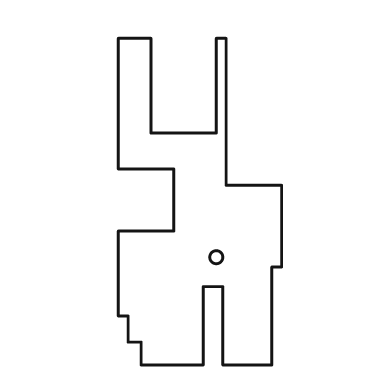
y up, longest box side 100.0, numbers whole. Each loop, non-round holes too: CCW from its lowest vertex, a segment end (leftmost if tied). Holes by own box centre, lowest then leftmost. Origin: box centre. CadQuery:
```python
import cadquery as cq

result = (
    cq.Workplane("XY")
    .moveTo(-18.0, -50.0)
    .lineTo(1.0, -50.0)
    .lineTo(1.0, -26.0)
    .lineTo(7.0, -26.0)
    .lineTo(7.0, -50.0)
    .lineTo(22.0, -50.0)
    .lineTo(22.0, -20.0)
    .lineTo(25.0, -20.0)
    .lineTo(25.0, 5.0)
    .lineTo(8.0, 5.0)
    .lineTo(8.0, 50.0)
    .lineTo(5.0, 50.0)
    .lineTo(5.0, 21.0)
    .lineTo(-15.0, 21.0)
    .lineTo(-15.0, 50.0)
    .lineTo(-25.0, 50.0)
    .lineTo(-25.0, 10.0)
    .lineTo(-8.0, 10.0)
    .lineTo(-8.0, -9.0)
    .lineTo(-25.0, -9.0)
    .lineTo(-25.0, -35.0)
    .lineTo(-22.0, -35.0)
    .lineTo(-22.0, -43.0)
    .lineTo(-18.0, -43.0)
    .close()
    .moveTo(5.0, -17.0)
    .circle(2.0)
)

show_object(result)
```